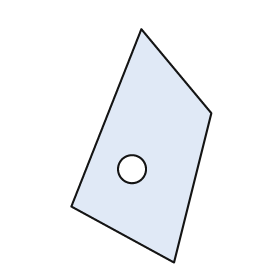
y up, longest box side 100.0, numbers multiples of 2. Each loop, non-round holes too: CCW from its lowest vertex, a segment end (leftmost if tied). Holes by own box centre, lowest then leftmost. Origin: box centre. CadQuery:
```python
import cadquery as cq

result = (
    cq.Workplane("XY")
    .moveTo(14.0, -50.0)
    .lineTo(30.0, 14.0)
    .lineTo(0.0, 50.0)
    .lineTo(-30.0, -26.0)
    .close()
    .moveTo(-4.0, -10.0)
    .circle(6.0)
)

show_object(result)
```